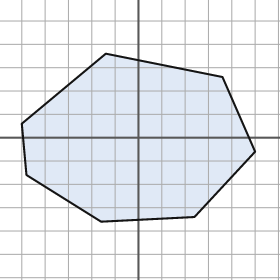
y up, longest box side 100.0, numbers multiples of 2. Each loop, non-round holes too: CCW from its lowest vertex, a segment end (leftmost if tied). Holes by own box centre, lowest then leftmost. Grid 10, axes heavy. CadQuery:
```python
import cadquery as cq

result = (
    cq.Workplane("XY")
    .moveTo(-16.0, -36.0)
    .lineTo(24.0, -34.0)
    .lineTo(50.0, -6.0)
    .lineTo(36.0, 26.0)
    .lineTo(-14.0, 36.0)
    .lineTo(-50.0, 6.0)
    .lineTo(-48.0, -16.0)
    .close()
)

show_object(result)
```